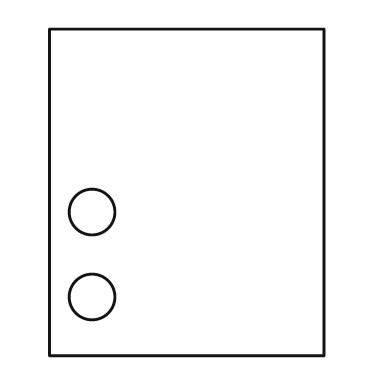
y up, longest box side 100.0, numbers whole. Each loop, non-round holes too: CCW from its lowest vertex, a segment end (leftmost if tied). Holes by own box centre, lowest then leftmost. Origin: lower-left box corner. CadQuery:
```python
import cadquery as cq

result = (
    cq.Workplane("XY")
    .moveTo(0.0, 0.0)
    .lineTo(84.0, 0.0)
    .lineTo(84.0, 100.0)
    .lineTo(0.0, 100.0)
    .close()
    .moveTo(13.0, 18.0)
    .circle(7.0)
    .moveTo(13.0, 44.0)
    .circle(7.0)
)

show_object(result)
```